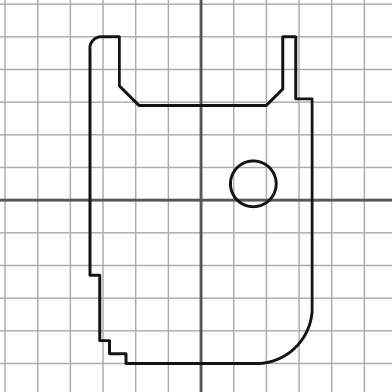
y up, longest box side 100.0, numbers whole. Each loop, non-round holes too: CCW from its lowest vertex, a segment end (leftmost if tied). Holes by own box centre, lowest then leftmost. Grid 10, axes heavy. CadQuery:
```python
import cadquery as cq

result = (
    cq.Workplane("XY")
    .moveTo(-23.0, -50.0)
    .lineTo(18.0, -50.0)
    .threePointArc((29.0, -45.0), (34.0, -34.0))
    .lineTo(34.0, 31.0)
    .lineTo(29.0, 31.0)
    .lineTo(29.0, 50.0)
    .lineTo(25.0, 50.0)
    .lineTo(25.0, 34.0)
    .lineTo(20.0, 29.0)
    .lineTo(-19.0, 29.0)
    .lineTo(-25.0, 35.0)
    .lineTo(-25.0, 50.0)
    .lineTo(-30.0, 50.0)
    .threePointArc((-33.0, 49.0), (-34.0, 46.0))
    .lineTo(-34.0, -23.0)
    .lineTo(-31.0, -23.0)
    .lineTo(-31.0, -43.0)
    .lineTo(-28.0, -43.0)
    .lineTo(-28.0, -47.0)
    .lineTo(-23.0, -47.0)
    .close()
    .moveTo(16.0, 5.0)
    .circle(7.0)
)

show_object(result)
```